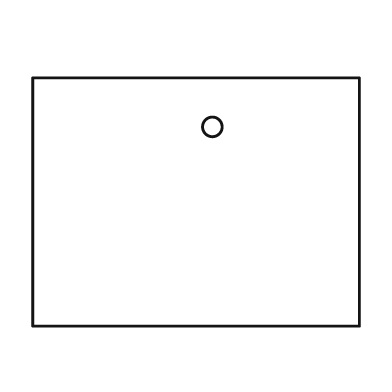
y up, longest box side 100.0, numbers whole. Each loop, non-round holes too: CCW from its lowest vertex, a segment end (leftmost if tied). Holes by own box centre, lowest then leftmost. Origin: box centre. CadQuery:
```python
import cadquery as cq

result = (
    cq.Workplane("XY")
    .moveTo(-50.0, -38.0)
    .lineTo(50.0, -38.0)
    .lineTo(50.0, 38.0)
    .lineTo(-50.0, 38.0)
    .close()
    .moveTo(5.0, 23.0)
    .circle(3.0)
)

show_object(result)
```